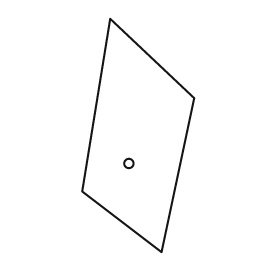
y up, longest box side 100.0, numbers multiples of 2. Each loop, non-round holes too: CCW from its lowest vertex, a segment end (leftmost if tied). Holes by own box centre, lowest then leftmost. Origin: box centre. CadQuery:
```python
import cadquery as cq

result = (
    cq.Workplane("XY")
    .moveTo(10.0, -50.0)
    .lineTo(24.0, 16.0)
    .lineTo(-12.0, 50.0)
    .lineTo(-24.0, -24.0)
    .close()
    .moveTo(-4.0, -12.0)
    .circle(2.0)
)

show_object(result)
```